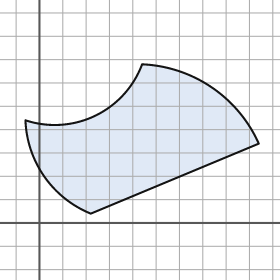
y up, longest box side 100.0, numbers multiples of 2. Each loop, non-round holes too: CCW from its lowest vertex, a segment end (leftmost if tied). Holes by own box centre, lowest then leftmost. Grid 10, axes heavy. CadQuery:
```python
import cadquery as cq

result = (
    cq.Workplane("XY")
    .moveTo(22.0, 4.0)
    .lineTo(94.0, 34.0)
    .threePointArc((74.0, 58.0), (44.0, 68.0))
    .threePointArc((24.0, 46.0), (-6.0, 44.0))
    .threePointArc((2.0, 20.0), (22.0, 4.0))
    .close()
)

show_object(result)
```